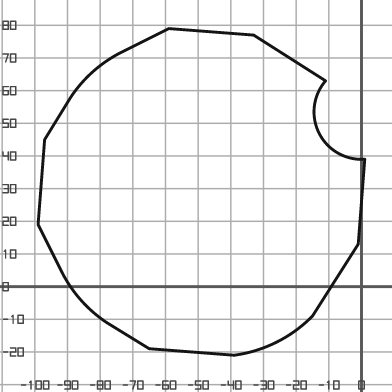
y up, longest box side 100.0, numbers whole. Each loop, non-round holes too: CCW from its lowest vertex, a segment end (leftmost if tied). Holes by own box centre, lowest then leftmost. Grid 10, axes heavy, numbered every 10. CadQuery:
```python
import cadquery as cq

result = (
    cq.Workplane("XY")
    .moveTo(-39.0, -21.0)
    .threePointArc((-26.0, -17.0), (-15.0, -9.0))
    .lineTo(-1.0, 13.0)
    .lineTo(1.0, 39.0)
    .threePointArc((-13.0, 47.0), (-11.0, 63.0))
    .lineTo(-33.0, 77.0)
    .lineTo(-59.0, 79.0)
    .lineTo(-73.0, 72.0)
    .threePointArc((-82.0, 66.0), (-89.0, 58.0))
    .lineTo(-97.0, 45.0)
    .lineTo(-99.0, 19.0)
    .lineTo(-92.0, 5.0)
    .threePointArc((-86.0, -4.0), (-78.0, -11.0))
    .lineTo(-65.0, -19.0)
    .close()
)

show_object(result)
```